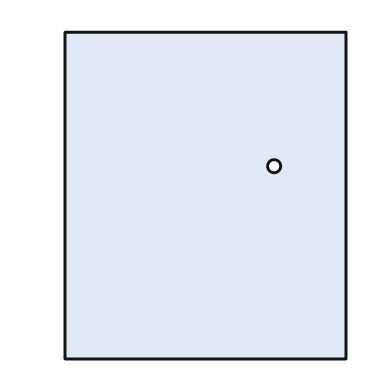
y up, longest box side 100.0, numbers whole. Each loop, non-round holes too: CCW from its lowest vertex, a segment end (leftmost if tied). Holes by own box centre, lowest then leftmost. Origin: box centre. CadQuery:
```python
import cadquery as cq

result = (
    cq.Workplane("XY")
    .moveTo(-43.0, -50.0)
    .lineTo(43.0, -50.0)
    .lineTo(43.0, 50.0)
    .lineTo(-43.0, 50.0)
    .close()
    .moveTo(21.0, 9.0)
    .circle(2.0)
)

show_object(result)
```